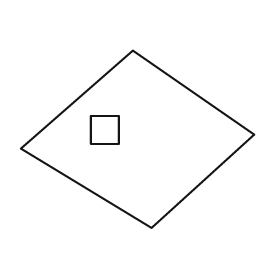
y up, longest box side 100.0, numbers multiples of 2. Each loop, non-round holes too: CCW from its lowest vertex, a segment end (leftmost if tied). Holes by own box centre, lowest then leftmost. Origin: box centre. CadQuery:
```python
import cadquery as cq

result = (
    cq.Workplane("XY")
    .moveTo(6.0, -38.0)
    .lineTo(50.0, 2.0)
    .lineTo(-2.0, 38.0)
    .lineTo(-50.0, -4.0)
    .close()
    .moveTo(-20.0, -2.0)
    .lineTo(-8.0, -2.0)
    .lineTo(-8.0, 10.0)
    .lineTo(-20.0, 10.0)
    .close()
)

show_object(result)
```